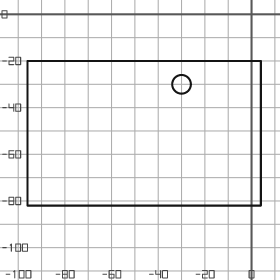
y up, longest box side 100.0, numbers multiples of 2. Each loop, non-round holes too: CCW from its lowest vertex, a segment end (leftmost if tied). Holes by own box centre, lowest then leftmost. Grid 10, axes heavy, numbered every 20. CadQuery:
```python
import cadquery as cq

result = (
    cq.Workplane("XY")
    .moveTo(-96.0, -82.0)
    .lineTo(4.0, -82.0)
    .lineTo(4.0, -20.0)
    .lineTo(-96.0, -20.0)
    .close()
    .moveTo(-30.0, -30.0)
    .circle(4.0)
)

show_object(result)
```